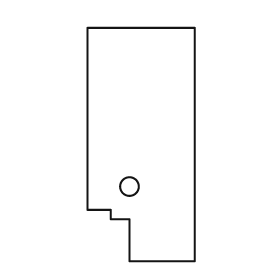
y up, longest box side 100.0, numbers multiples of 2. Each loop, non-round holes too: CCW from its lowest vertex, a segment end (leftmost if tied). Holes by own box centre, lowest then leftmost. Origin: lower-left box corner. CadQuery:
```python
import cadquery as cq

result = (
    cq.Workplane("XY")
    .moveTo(18.0, 0.0)
    .lineTo(46.0, 0.0)
    .lineTo(46.0, 100.0)
    .lineTo(0.0, 100.0)
    .lineTo(0.0, 22.0)
    .lineTo(10.0, 22.0)
    .lineTo(10.0, 18.0)
    .lineTo(18.0, 18.0)
    .close()
    .moveTo(18.0, 32.0)
    .circle(4.0)
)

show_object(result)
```